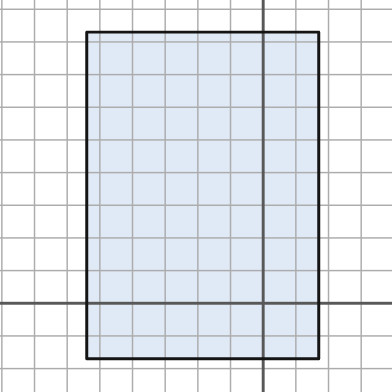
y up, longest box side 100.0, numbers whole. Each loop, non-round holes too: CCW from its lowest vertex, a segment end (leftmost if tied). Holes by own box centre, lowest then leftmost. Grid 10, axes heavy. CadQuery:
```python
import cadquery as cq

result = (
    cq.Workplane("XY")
    .moveTo(-54.0, -17.0)
    .lineTo(17.0, -17.0)
    .lineTo(17.0, 83.0)
    .lineTo(-54.0, 83.0)
    .close()
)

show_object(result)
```